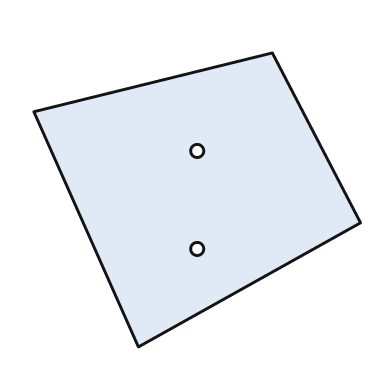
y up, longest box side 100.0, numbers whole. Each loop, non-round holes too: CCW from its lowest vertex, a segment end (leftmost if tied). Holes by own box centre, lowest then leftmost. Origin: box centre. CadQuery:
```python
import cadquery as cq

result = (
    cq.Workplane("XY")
    .moveTo(-18.0, -45.0)
    .lineTo(50.0, -7.0)
    .lineTo(23.0, 45.0)
    .lineTo(-50.0, 27.0)
    .close()
    .moveTo(0.0, -15.0)
    .circle(2.0)
    .moveTo(0.0, 15.0)
    .circle(2.0)
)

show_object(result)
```